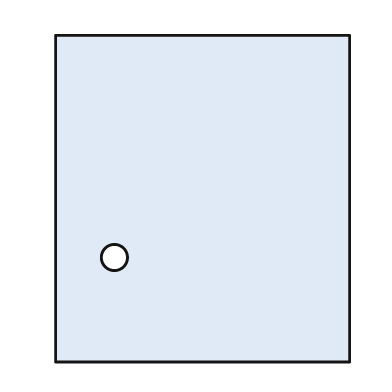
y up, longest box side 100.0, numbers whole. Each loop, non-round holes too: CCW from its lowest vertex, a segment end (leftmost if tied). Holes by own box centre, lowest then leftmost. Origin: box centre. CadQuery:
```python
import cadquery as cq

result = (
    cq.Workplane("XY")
    .moveTo(-45.0, -50.0)
    .lineTo(45.0, -50.0)
    .lineTo(45.0, 50.0)
    .lineTo(-45.0, 50.0)
    .close()
    .moveTo(-27.0, -18.0)
    .circle(4.0)
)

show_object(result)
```